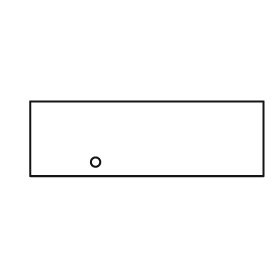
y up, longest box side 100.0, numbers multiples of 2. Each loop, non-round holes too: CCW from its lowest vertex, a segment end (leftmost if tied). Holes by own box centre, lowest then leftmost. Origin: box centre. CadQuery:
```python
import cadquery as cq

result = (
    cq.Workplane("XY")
    .moveTo(-50.0, -16.0)
    .lineTo(50.0, -16.0)
    .lineTo(50.0, 16.0)
    .lineTo(-50.0, 16.0)
    .close()
    .moveTo(-22.0, -10.0)
    .circle(2.0)
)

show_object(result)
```